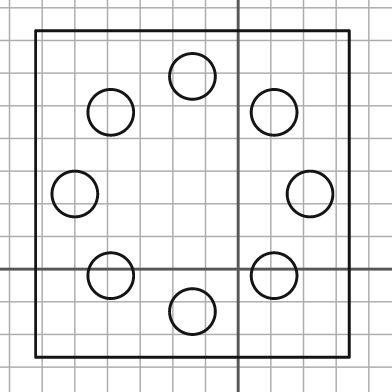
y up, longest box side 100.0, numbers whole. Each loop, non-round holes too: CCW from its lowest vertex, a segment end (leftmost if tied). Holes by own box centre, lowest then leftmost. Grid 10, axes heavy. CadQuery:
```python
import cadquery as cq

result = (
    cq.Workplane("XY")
    .moveTo(-62.0, -27.0)
    .lineTo(34.0, -27.0)
    .lineTo(34.0, 73.0)
    .lineTo(-62.0, 73.0)
    .close()
    .moveTo(-14.0, -13.0)
    .circle(7.0)
    .moveTo(-39.0, -2.0)
    .circle(7.0)
    .moveTo(11.0, -2.0)
    .circle(7.0)
    .moveTo(-50.0, 23.0)
    .circle(7.0)
    .moveTo(22.0, 23.0)
    .circle(7.0)
    .moveTo(-39.0, 48.0)
    .circle(7.0)
    .moveTo(11.0, 48.0)
    .circle(7.0)
    .moveTo(-14.0, 59.0)
    .circle(7.0)
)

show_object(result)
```